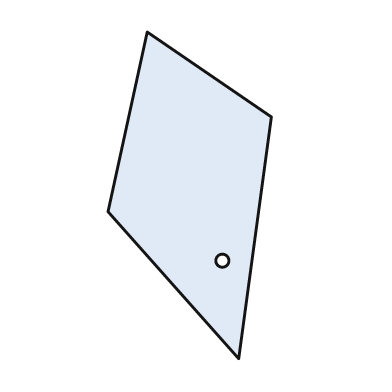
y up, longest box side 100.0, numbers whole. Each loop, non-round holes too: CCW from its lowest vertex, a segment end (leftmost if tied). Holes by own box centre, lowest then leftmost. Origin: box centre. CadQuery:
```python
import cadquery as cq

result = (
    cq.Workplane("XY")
    .moveTo(15.0, -50.0)
    .lineTo(25.0, 24.0)
    .lineTo(-13.0, 50.0)
    .lineTo(-25.0, -5.0)
    .close()
    .moveTo(10.0, -20.0)
    .circle(2.0)
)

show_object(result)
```